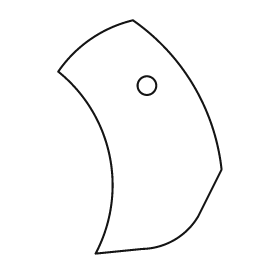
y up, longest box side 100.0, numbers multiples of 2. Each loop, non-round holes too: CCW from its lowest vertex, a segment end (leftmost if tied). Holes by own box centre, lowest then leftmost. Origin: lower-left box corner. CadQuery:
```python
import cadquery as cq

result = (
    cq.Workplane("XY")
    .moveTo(16.0, 0.0)
    .lineTo(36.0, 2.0)
    .threePointArc((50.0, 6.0), (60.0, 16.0))
    .lineTo(70.0, 36.0)
    .threePointArc((58.0, 72.0), (32.0, 100.0))
    .threePointArc((14.0, 92.0), (0.0, 78.0))
    .threePointArc((22.0, 42.0), (16.0, 0.0))
    .close()
    .moveTo(38.0, 72.0)
    .circle(4.0)
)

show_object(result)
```